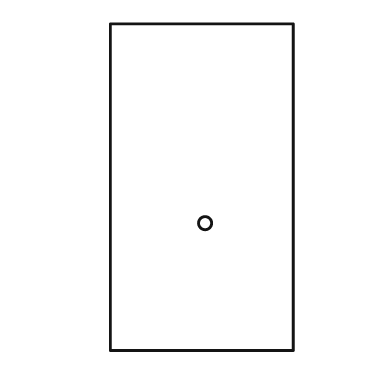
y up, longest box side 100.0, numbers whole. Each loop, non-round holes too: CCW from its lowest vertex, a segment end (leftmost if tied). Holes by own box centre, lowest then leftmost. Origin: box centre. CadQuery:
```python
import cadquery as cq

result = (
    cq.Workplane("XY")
    .moveTo(-28.0, -50.0)
    .lineTo(28.0, -50.0)
    .lineTo(28.0, 50.0)
    .lineTo(-28.0, 50.0)
    .close()
    .moveTo(1.0, -11.0)
    .circle(2.0)
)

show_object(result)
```